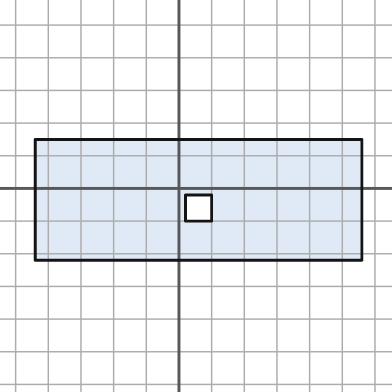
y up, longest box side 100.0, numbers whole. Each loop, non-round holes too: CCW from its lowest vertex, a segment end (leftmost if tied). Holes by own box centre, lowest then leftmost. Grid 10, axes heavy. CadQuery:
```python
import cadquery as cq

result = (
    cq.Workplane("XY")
    .moveTo(-44.0, -22.0)
    .lineTo(56.0, -22.0)
    .lineTo(56.0, 15.0)
    .lineTo(-44.0, 15.0)
    .close()
    .moveTo(2.0, -10.0)
    .lineTo(10.0, -10.0)
    .lineTo(10.0, -2.0)
    .lineTo(2.0, -2.0)
    .close()
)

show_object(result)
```